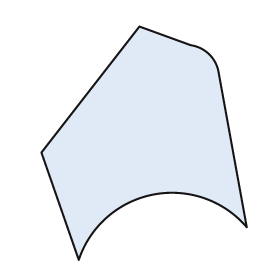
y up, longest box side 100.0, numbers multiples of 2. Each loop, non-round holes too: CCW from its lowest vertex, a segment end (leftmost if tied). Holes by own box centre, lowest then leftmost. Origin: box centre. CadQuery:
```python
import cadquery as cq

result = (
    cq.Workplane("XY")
    .moveTo(-28.0, -50.0)
    .threePointArc((4.0, -22.0), (44.0, -36.0))
    .lineTo(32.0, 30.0)
    .threePointArc((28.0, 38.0), (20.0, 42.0))
    .lineTo(-2.0, 50.0)
    .lineTo(-44.0, -4.0)
    .close()
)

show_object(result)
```